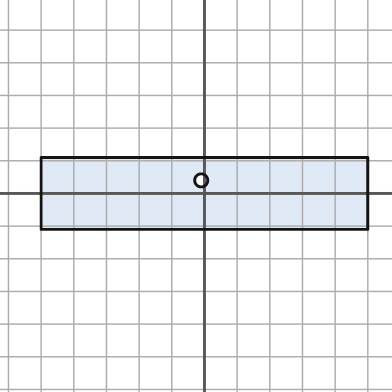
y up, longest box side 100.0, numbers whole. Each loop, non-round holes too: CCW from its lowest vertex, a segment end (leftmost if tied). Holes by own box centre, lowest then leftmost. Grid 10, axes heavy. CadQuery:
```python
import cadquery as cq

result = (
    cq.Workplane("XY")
    .moveTo(-50.0, -11.0)
    .lineTo(50.0, -11.0)
    .lineTo(50.0, 11.0)
    .lineTo(-50.0, 11.0)
    .close()
    .moveTo(-1.0, 4.0)
    .circle(2.0)
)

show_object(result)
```